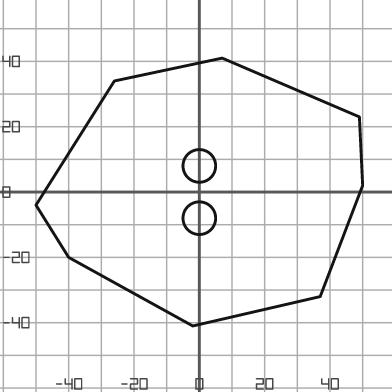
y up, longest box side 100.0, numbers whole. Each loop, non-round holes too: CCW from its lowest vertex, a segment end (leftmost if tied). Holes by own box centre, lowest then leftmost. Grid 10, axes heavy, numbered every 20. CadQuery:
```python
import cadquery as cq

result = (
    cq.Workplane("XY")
    .moveTo(-2.0, -41.0)
    .lineTo(37.0, -32.0)
    .lineTo(50.0, 2.0)
    .lineTo(49.0, 23.0)
    .lineTo(7.0, 41.0)
    .lineTo(-26.0, 34.0)
    .lineTo(-50.0, -4.0)
    .lineTo(-40.0, -20.0)
    .close()
    .moveTo(0.0, -8.0)
    .circle(5.0)
    .moveTo(0.0, 8.0)
    .circle(5.0)
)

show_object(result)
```